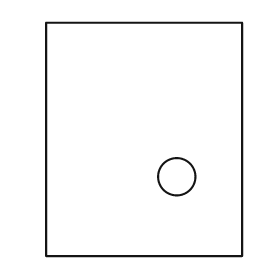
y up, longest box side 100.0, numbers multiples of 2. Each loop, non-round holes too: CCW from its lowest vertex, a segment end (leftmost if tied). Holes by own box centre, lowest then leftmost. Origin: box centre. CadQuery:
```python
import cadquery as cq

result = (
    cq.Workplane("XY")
    .moveTo(-42.0, -50.0)
    .lineTo(42.0, -50.0)
    .lineTo(42.0, 50.0)
    .lineTo(-42.0, 50.0)
    .close()
    .moveTo(14.0, -16.0)
    .circle(8.0)
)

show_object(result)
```